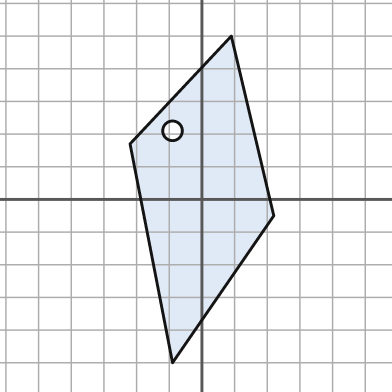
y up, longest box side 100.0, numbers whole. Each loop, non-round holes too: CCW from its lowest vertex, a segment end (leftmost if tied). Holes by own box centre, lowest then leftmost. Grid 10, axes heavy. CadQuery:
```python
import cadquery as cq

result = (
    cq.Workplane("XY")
    .moveTo(-9.0, -50.0)
    .lineTo(22.0, -5.0)
    .lineTo(9.0, 50.0)
    .lineTo(-22.0, 17.0)
    .close()
    .moveTo(-9.0, 21.0)
    .circle(3.0)
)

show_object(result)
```